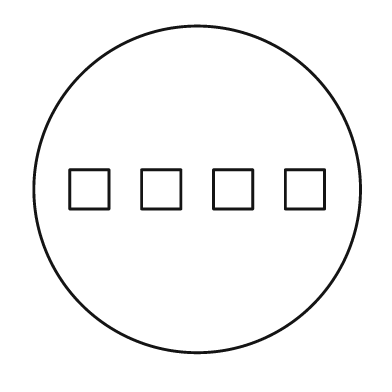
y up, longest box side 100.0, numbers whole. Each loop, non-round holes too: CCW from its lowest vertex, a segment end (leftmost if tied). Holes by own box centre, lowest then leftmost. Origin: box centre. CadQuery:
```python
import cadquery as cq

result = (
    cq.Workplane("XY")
    .moveTo(0.0, 0.0)
    .circle(50.0)
    .moveTo(-39.0, -6.0)
    .lineTo(-27.0, -6.0)
    .lineTo(-27.0, 6.0)
    .lineTo(-39.0, 6.0)
    .close()
    .moveTo(-17.0, -6.0)
    .lineTo(-5.0, -6.0)
    .lineTo(-5.0, 6.0)
    .lineTo(-17.0, 6.0)
    .close()
    .moveTo(5.0, -6.0)
    .lineTo(17.0, -6.0)
    .lineTo(17.0, 6.0)
    .lineTo(5.0, 6.0)
    .close()
    .moveTo(27.0, -6.0)
    .lineTo(39.0, -6.0)
    .lineTo(39.0, 6.0)
    .lineTo(27.0, 6.0)
    .close()
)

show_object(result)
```